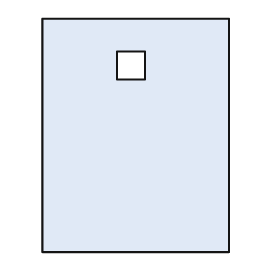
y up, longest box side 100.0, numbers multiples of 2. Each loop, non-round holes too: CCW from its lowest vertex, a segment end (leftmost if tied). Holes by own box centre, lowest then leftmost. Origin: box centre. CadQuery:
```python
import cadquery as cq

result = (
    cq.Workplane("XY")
    .moveTo(-40.0, -50.0)
    .lineTo(40.0, -50.0)
    .lineTo(40.0, 50.0)
    .lineTo(-40.0, 50.0)
    .close()
    .moveTo(-8.0, 24.0)
    .lineTo(4.0, 24.0)
    .lineTo(4.0, 36.0)
    .lineTo(-8.0, 36.0)
    .close()
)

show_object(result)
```